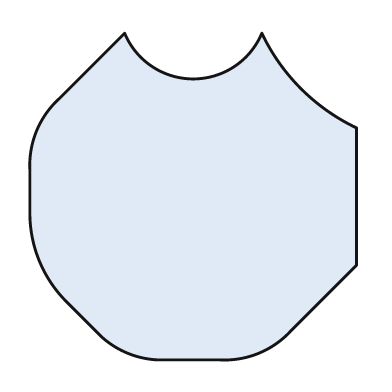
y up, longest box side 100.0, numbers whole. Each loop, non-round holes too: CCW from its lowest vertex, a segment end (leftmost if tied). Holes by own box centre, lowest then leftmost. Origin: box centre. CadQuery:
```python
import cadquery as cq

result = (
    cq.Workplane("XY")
    .moveTo(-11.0, -50.0)
    .lineTo(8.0, -50.0)
    .threePointArc((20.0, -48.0), (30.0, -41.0))
    .lineTo(50.0, -21.0)
    .lineTo(50.0, 21.0)
    .threePointArc((33.0, 33.0), (21.0, 50.0))
    .threePointArc((0.0, 36.0), (-21.0, 50.0))
    .lineTo(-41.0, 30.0)
    .threePointArc((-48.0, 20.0), (-50.0, 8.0))
    .lineTo(-50.0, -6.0)
    .threePointArc((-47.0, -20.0), (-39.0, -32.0))
    .lineTo(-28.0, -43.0)
    .threePointArc((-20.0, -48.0), (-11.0, -50.0))
    .close()
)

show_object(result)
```